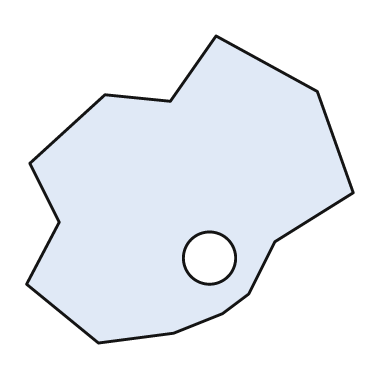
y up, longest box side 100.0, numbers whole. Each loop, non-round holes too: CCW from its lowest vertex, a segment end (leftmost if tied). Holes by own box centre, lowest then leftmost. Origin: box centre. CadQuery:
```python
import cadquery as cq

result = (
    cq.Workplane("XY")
    .moveTo(-28.0, -47.0)
    .lineTo(-5.0, -44.0)
    .lineTo(10.0, -38.0)
    .lineTo(18.0, -32.0)
    .lineTo(26.0, -16.0)
    .lineTo(50.0, -1.0)
    .lineTo(39.0, 30.0)
    .lineTo(8.0, 47.0)
    .lineTo(-6.0, 27.0)
    .lineTo(-26.0, 29.0)
    .lineTo(-49.0, 8.0)
    .lineTo(-40.0, -10.0)
    .lineTo(-50.0, -29.0)
    .close()
    .moveTo(6.0, -21.0)
    .circle(8.0)
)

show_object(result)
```